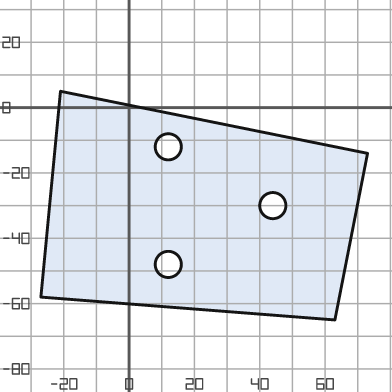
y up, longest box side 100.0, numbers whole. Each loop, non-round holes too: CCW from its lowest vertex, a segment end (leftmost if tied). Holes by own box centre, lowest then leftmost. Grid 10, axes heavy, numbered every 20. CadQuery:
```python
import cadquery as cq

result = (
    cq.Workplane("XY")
    .moveTo(63.0, -65.0)
    .lineTo(73.0, -14.0)
    .lineTo(-21.0, 5.0)
    .lineTo(-27.0, -58.0)
    .close()
    .moveTo(12.0, -48.0)
    .circle(4.0)
    .moveTo(44.0, -30.0)
    .circle(4.0)
    .moveTo(12.0, -12.0)
    .circle(4.0)
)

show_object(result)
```